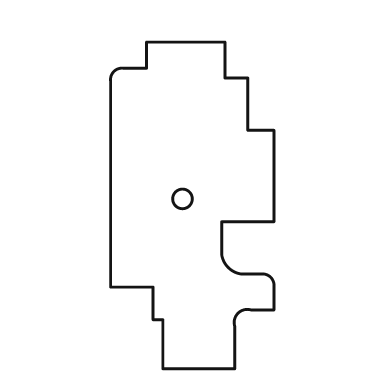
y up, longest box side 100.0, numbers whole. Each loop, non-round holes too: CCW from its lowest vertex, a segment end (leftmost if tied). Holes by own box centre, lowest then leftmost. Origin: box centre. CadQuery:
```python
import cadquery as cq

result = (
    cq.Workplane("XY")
    .moveTo(-9.0, -50.0)
    .lineTo(13.0, -50.0)
    .lineTo(13.0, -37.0)
    .threePointArc((14.0, -33.0), (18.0, -32.0))
    .lineTo(25.0, -32.0)
    .lineTo(25.0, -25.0)
    .threePointArc((24.0, -22.0), (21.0, -21.0))
    .lineTo(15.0, -21.0)
    .threePointArc((11.0, -19.0), (9.0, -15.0))
    .lineTo(9.0, -5.0)
    .lineTo(25.0, -5.0)
    .lineTo(25.0, 23.0)
    .lineTo(17.0, 23.0)
    .lineTo(17.0, 39.0)
    .lineTo(10.0, 39.0)
    .lineTo(10.0, 50.0)
    .lineTo(-14.0, 50.0)
    .lineTo(-14.0, 42.0)
    .lineTo(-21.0, 42.0)
    .threePointArc((-24.0, 41.0), (-25.0, 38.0))
    .lineTo(-25.0, -25.0)
    .lineTo(-12.0, -25.0)
    .lineTo(-12.0, -35.0)
    .lineTo(-9.0, -35.0)
    .close()
    .moveTo(-3.0, 2.0)
    .circle(3.0)
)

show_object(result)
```